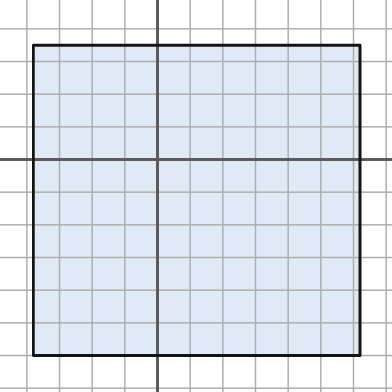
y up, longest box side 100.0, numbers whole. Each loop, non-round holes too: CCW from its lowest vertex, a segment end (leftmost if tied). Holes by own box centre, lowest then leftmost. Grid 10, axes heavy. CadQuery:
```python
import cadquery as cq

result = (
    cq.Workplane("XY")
    .moveTo(-38.0, -60.0)
    .lineTo(62.0, -60.0)
    .lineTo(62.0, 35.0)
    .lineTo(-38.0, 35.0)
    .close()
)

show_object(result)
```